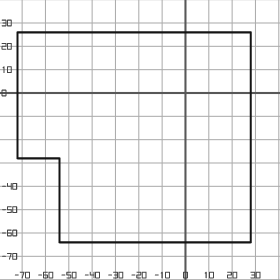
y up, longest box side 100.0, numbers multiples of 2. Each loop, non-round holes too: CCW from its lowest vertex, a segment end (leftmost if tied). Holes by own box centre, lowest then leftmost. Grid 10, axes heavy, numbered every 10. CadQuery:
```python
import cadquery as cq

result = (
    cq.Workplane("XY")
    .moveTo(-54.0, -64.0)
    .lineTo(28.0, -64.0)
    .lineTo(28.0, 26.0)
    .lineTo(-72.0, 26.0)
    .lineTo(-72.0, -28.0)
    .lineTo(-54.0, -28.0)
    .close()
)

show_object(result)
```